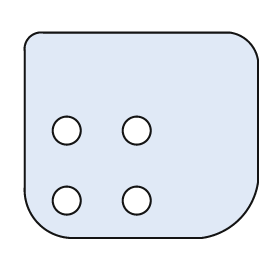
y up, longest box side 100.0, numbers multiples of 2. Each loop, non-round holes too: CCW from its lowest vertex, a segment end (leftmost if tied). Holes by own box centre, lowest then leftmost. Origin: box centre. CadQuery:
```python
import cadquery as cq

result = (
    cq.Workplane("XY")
    .moveTo(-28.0, -44.0)
    .lineTo(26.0, -44.0)
    .threePointArc((42.0, -36.0), (50.0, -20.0))
    .lineTo(50.0, 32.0)
    .threePointArc((46.0, 40.0), (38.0, 44.0))
    .lineTo(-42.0, 44.0)
    .threePointArc((-48.0, 42.0), (-50.0, 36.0))
    .lineTo(-50.0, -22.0)
    .threePointArc((-44.0, -38.0), (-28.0, -44.0))
    .close()
    .moveTo(-32.0, -28.0)
    .circle(6.0)
    .moveTo(-2.0, -28.0)
    .circle(6.0)
    .moveTo(-32.0, 2.0)
    .circle(6.0)
    .moveTo(-2.0, 2.0)
    .circle(6.0)
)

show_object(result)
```